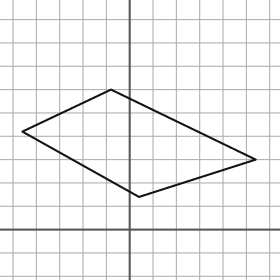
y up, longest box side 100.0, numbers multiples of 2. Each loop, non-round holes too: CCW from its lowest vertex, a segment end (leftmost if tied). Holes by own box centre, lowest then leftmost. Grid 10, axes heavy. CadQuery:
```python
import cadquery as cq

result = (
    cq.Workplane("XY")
    .moveTo(4.0, 14.0)
    .lineTo(54.0, 30.0)
    .lineTo(-8.0, 60.0)
    .lineTo(-46.0, 42.0)
    .close()
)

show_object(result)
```